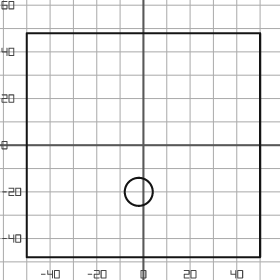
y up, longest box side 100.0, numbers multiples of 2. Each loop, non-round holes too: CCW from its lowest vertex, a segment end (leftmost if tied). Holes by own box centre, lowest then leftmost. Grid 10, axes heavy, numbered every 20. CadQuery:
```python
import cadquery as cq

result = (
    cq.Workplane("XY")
    .moveTo(-50.0, -48.0)
    .lineTo(50.0, -48.0)
    .lineTo(50.0, 48.0)
    .lineTo(-50.0, 48.0)
    .close()
    .moveTo(-2.0, -20.0)
    .circle(6.0)
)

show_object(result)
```